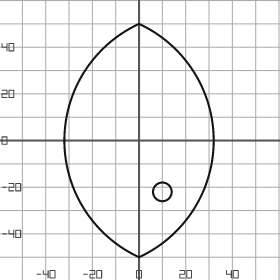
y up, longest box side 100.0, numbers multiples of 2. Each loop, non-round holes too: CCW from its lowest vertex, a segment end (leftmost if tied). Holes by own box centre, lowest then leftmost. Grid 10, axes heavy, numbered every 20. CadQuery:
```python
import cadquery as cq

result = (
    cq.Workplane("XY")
    .moveTo(0.0, -50.0)
    .threePointArc((32.0, 0.0), (0.0, 50.0))
    .threePointArc((-32.0, 0.0), (0.0, -50.0))
    .close()
    .moveTo(10.0, -22.0)
    .circle(4.0)
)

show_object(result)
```